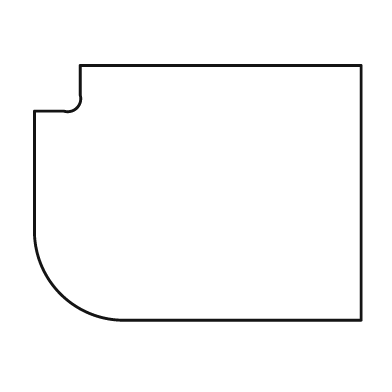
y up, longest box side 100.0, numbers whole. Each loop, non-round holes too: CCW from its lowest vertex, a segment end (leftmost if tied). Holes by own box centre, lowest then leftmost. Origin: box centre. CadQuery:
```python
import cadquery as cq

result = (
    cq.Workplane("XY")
    .moveTo(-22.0, -39.0)
    .lineTo(50.0, -39.0)
    .lineTo(50.0, 39.0)
    .lineTo(-36.0, 39.0)
    .lineTo(-36.0, 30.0)
    .threePointArc((-37.0, 26.0), (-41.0, 25.0))
    .lineTo(-50.0, 25.0)
    .lineTo(-50.0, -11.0)
    .threePointArc((-42.0, -31.0), (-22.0, -39.0))
    .close()
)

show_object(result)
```